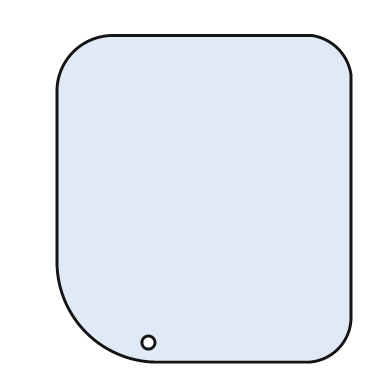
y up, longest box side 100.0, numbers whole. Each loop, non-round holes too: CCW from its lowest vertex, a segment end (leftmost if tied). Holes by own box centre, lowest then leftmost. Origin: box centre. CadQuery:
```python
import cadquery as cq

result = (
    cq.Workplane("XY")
    .moveTo(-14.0, -50.0)
    .lineTo(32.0, -50.0)
    .threePointArc((41.0, -46.0), (45.0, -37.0))
    .lineTo(45.0, 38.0)
    .threePointArc((41.0, 46.0), (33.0, 50.0))
    .lineTo(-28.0, 50.0)
    .threePointArc((-40.0, 45.0), (-45.0, 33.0))
    .lineTo(-45.0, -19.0)
    .threePointArc((-36.0, -41.0), (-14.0, -50.0))
    .close()
    .moveTo(-17.0, -44.0)
    .circle(2.0)
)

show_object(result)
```